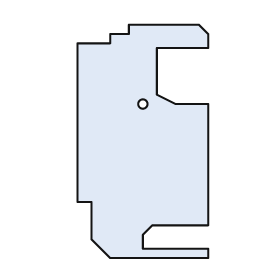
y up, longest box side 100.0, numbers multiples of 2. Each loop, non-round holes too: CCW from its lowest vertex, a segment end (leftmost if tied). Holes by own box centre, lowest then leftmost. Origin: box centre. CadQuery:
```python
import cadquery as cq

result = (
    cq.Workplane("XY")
    .moveTo(-14.0, -50.0)
    .lineTo(28.0, -50.0)
    .lineTo(28.0, -46.0)
    .lineTo(0.0, -46.0)
    .lineTo(0.0, -40.0)
    .lineTo(4.0, -36.0)
    .lineTo(28.0, -36.0)
    .lineTo(28.0, 16.0)
    .lineTo(14.0, 16.0)
    .lineTo(6.0, 20.0)
    .lineTo(6.0, 40.0)
    .lineTo(28.0, 40.0)
    .lineTo(28.0, 46.0)
    .lineTo(24.0, 50.0)
    .lineTo(-6.0, 50.0)
    .lineTo(-6.0, 46.0)
    .lineTo(-14.0, 46.0)
    .lineTo(-14.0, 42.0)
    .lineTo(-28.0, 42.0)
    .lineTo(-28.0, -26.0)
    .lineTo(-22.0, -26.0)
    .lineTo(-22.0, -42.0)
    .close()
    .moveTo(0.0, 16.0)
    .circle(2.0)
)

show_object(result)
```